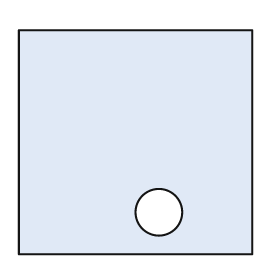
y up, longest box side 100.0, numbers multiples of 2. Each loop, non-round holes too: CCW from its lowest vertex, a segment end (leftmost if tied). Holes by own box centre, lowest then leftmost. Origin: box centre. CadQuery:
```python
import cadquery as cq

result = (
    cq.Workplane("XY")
    .moveTo(-50.0, -48.0)
    .lineTo(50.0, -48.0)
    .lineTo(50.0, 48.0)
    .lineTo(-50.0, 48.0)
    .close()
    .moveTo(10.0, -30.0)
    .circle(10.0)
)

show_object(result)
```